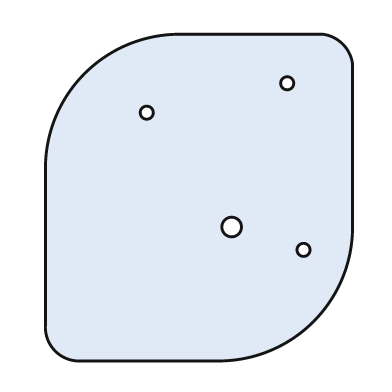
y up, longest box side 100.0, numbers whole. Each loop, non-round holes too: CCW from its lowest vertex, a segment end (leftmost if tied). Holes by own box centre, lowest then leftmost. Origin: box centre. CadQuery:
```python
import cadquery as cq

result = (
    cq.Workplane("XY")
    .moveTo(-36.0, -50.0)
    .lineTo(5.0, -50.0)
    .threePointArc((35.0, -38.0), (47.0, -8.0))
    .lineTo(47.0, 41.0)
    .threePointArc((44.0, 47.0), (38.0, 50.0))
    .lineTo(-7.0, 50.0)
    .threePointArc((-35.0, 38.0), (-47.0, 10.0))
    .lineTo(-47.0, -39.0)
    .threePointArc((-44.0, -47.0), (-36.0, -50.0))
    .close()
    .moveTo(32.0, -16.0)
    .circle(2.0)
    .moveTo(10.0, -9.0)
    .circle(3.0)
    .moveTo(-16.0, 26.0)
    .circle(2.0)
    .moveTo(27.0, 35.0)
    .circle(2.0)
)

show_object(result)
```